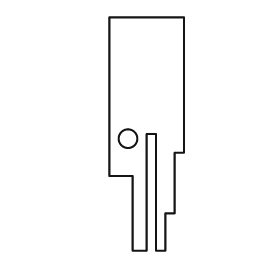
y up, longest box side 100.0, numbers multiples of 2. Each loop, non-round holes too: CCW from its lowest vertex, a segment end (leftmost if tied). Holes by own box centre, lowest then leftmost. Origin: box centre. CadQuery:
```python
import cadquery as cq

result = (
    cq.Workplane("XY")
    .moveTo(-6.0, -50.0)
    .lineTo(0.0, -50.0)
    .lineTo(0.0, 0.0)
    .lineTo(4.0, 0.0)
    .lineTo(4.0, -50.0)
    .lineTo(8.0, -50.0)
    .lineTo(8.0, -34.0)
    .lineTo(12.0, -34.0)
    .lineTo(12.0, -8.0)
    .lineTo(16.0, -8.0)
    .lineTo(16.0, 50.0)
    .lineTo(-16.0, 50.0)
    .lineTo(-16.0, -18.0)
    .lineTo(-6.0, -18.0)
    .close()
    .moveTo(-8.0, -2.0)
    .circle(4.0)
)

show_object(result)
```